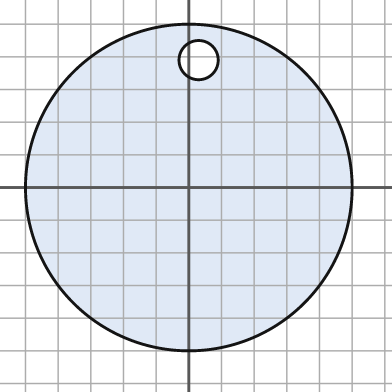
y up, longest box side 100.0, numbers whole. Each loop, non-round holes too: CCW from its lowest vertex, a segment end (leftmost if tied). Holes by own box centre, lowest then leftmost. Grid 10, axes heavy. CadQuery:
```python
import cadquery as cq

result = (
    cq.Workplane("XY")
    .moveTo(0.0, 0.0)
    .circle(50.0)
    .moveTo(3.0, 39.0)
    .circle(6.0)
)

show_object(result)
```